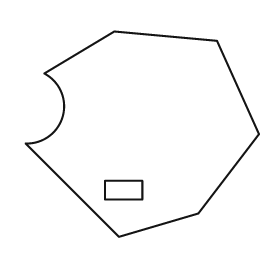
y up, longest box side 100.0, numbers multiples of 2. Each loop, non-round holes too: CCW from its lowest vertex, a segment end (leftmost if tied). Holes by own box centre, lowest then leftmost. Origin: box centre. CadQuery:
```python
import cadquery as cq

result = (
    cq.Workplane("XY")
    .moveTo(-10.0, -44.0)
    .lineTo(24.0, -34.0)
    .lineTo(50.0, 0.0)
    .lineTo(32.0, 40.0)
    .lineTo(-12.0, 44.0)
    .lineTo(-42.0, 26.0)
    .threePointArc((-34.0, 8.0), (-50.0, -4.0))
    .close()
    .moveTo(-16.0, -28.0)
    .lineTo(0.0, -28.0)
    .lineTo(0.0, -20.0)
    .lineTo(-16.0, -20.0)
    .close()
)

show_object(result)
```